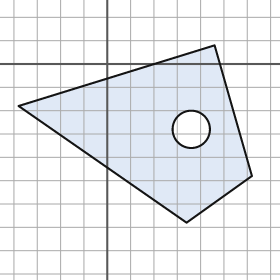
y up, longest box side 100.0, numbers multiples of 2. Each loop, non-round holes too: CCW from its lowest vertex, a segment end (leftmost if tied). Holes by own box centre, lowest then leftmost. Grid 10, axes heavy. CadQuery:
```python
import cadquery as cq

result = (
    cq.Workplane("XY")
    .moveTo(34.0, -68.0)
    .lineTo(62.0, -48.0)
    .lineTo(46.0, 8.0)
    .lineTo(-38.0, -18.0)
    .close()
    .moveTo(36.0, -28.0)
    .circle(8.0)
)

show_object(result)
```